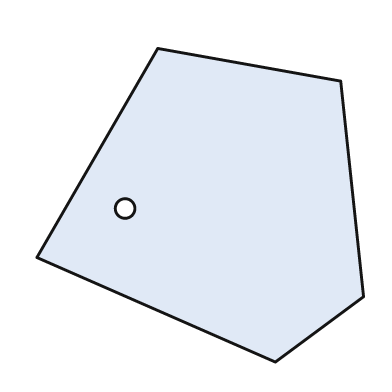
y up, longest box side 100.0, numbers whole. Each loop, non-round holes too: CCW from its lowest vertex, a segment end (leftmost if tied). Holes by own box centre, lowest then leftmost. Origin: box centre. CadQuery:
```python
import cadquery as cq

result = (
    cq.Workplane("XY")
    .moveTo(23.0, -48.0)
    .lineTo(50.0, -28.0)
    .lineTo(43.0, 38.0)
    .lineTo(-13.0, 48.0)
    .lineTo(-50.0, -16.0)
    .close()
    .moveTo(-23.0, -1.0)
    .circle(3.0)
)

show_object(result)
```